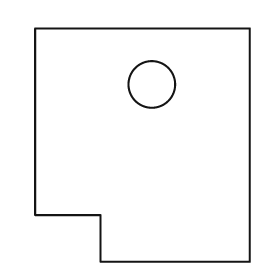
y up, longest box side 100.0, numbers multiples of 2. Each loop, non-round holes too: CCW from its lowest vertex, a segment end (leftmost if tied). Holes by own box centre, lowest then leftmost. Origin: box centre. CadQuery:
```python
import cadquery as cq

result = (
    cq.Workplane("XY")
    .moveTo(-18.0, -50.0)
    .lineTo(46.0, -50.0)
    .lineTo(46.0, 50.0)
    .lineTo(-46.0, 50.0)
    .lineTo(-46.0, -30.0)
    .lineTo(-18.0, -30.0)
    .close()
    .moveTo(4.0, 26.0)
    .circle(10.0)
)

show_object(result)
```